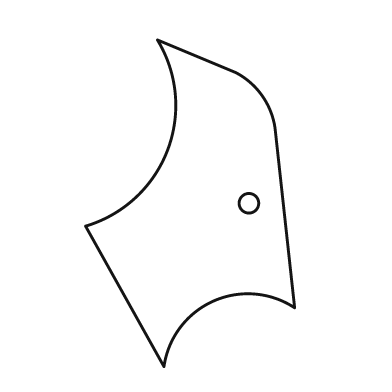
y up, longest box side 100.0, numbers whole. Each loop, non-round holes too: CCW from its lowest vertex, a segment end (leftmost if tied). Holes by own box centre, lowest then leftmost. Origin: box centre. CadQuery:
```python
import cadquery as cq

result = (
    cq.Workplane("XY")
    .moveTo(-8.0, -50.0)
    .threePointArc((7.0, -30.0), (32.0, -32.0))
    .lineTo(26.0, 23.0)
    .threePointArc((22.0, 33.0), (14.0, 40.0))
    .lineTo(-10.0, 50.0)
    .threePointArc((-7.0, 16.0), (-32.0, -7.0))
    .close()
    .moveTo(18.0, 0.0)
    .circle(3.0)
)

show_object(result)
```